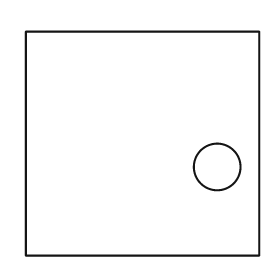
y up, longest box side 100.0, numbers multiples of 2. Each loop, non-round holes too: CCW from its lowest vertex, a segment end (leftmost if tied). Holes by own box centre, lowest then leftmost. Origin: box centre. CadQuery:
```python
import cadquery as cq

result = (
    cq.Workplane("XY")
    .moveTo(-50.0, -48.0)
    .lineTo(50.0, -48.0)
    .lineTo(50.0, 48.0)
    .lineTo(-50.0, 48.0)
    .close()
    .moveTo(32.0, -10.0)
    .circle(10.0)
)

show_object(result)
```